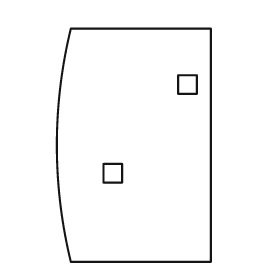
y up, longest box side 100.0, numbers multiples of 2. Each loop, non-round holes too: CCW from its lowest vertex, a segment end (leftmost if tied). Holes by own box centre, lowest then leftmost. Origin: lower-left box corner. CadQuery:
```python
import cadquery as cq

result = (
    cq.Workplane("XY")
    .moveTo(6.0, 0.0)
    .lineTo(66.0, 0.0)
    .lineTo(66.0, 100.0)
    .lineTo(6.0, 100.0)
    .threePointArc((0.0, 50.0), (6.0, 0.0))
    .close()
    .moveTo(20.0, 34.0)
    .lineTo(28.0, 34.0)
    .lineTo(28.0, 42.0)
    .lineTo(20.0, 42.0)
    .close()
    .moveTo(52.0, 72.0)
    .lineTo(60.0, 72.0)
    .lineTo(60.0, 80.0)
    .lineTo(52.0, 80.0)
    .close()
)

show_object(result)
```